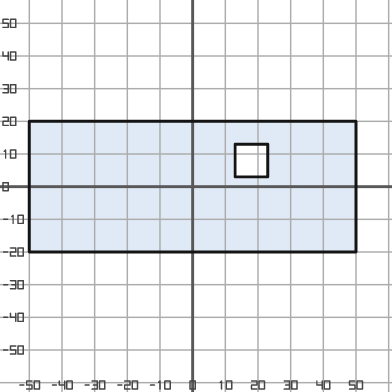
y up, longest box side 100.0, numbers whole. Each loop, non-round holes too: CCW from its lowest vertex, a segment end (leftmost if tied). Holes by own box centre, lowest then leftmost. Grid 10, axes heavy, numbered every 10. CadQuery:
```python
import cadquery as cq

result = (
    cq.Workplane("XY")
    .moveTo(-50.0, -20.0)
    .lineTo(50.0, -20.0)
    .lineTo(50.0, 20.0)
    .lineTo(-50.0, 20.0)
    .close()
    .moveTo(13.0, 3.0)
    .lineTo(23.0, 3.0)
    .lineTo(23.0, 13.0)
    .lineTo(13.0, 13.0)
    .close()
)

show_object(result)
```